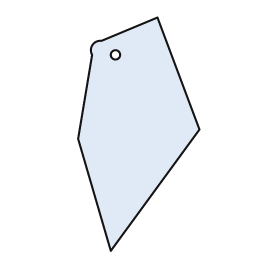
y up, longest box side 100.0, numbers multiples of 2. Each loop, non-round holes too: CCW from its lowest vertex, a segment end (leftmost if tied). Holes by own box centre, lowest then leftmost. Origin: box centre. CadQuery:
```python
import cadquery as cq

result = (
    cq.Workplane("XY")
    .moveTo(-12.0, -50.0)
    .lineTo(26.0, 2.0)
    .lineTo(8.0, 50.0)
    .lineTo(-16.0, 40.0)
    .threePointArc((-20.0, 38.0), (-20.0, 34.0))
    .lineTo(-26.0, -2.0)
    .close()
    .moveTo(-10.0, 34.0)
    .circle(2.0)
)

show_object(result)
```